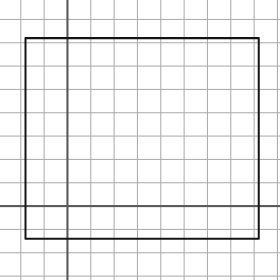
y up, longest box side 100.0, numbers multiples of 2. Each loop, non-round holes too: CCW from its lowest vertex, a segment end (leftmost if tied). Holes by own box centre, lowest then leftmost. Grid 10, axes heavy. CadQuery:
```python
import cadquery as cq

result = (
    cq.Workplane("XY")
    .moveTo(-18.0, -14.0)
    .lineTo(82.0, -14.0)
    .lineTo(82.0, 72.0)
    .lineTo(-18.0, 72.0)
    .close()
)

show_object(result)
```